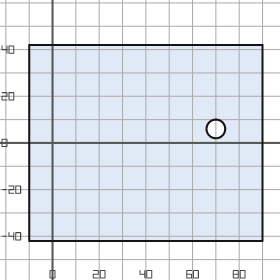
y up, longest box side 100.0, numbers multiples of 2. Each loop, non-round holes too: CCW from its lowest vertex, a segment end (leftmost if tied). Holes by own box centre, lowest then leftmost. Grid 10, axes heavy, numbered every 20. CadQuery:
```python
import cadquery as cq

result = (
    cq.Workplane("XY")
    .moveTo(-10.0, -42.0)
    .lineTo(90.0, -42.0)
    .lineTo(90.0, 42.0)
    .lineTo(-10.0, 42.0)
    .close()
    .moveTo(70.0, 6.0)
    .circle(4.0)
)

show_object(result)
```